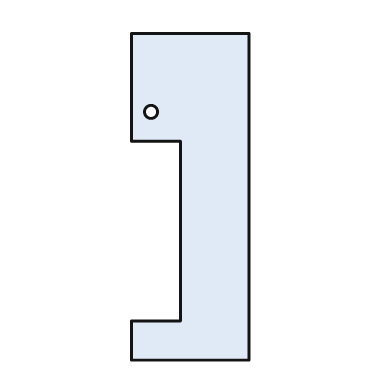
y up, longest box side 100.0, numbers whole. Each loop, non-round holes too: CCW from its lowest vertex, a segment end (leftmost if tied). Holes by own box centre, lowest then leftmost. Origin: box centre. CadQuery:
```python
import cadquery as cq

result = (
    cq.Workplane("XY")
    .moveTo(-18.0, -50.0)
    .lineTo(18.0, -50.0)
    .lineTo(18.0, 50.0)
    .lineTo(-18.0, 50.0)
    .lineTo(-18.0, 17.0)
    .lineTo(-3.0, 17.0)
    .lineTo(-3.0, -38.0)
    .lineTo(-18.0, -38.0)
    .close()
    .moveTo(-12.0, 26.0)
    .circle(2.0)
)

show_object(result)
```